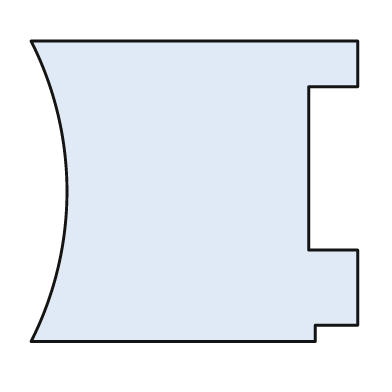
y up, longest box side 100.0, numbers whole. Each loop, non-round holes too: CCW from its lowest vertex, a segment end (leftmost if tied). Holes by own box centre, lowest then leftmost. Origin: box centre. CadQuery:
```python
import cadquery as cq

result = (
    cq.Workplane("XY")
    .moveTo(-50.0, -46.0)
    .lineTo(37.0, -46.0)
    .lineTo(37.0, -41.0)
    .lineTo(50.0, -41.0)
    .lineTo(50.0, -18.0)
    .lineTo(35.0, -18.0)
    .lineTo(35.0, 32.0)
    .lineTo(50.0, 32.0)
    .lineTo(50.0, 46.0)
    .lineTo(-50.0, 46.0)
    .threePointArc((-39.0, 0.0), (-50.0, -46.0))
    .close()
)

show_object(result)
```